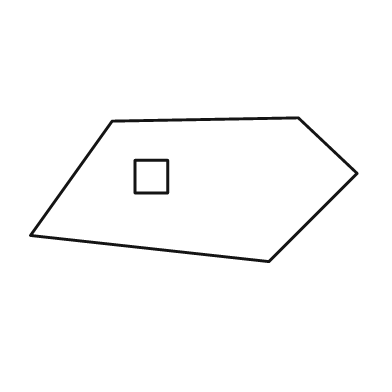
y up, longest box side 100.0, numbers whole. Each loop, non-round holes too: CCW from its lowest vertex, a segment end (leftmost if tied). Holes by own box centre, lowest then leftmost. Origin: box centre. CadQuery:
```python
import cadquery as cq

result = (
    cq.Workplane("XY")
    .moveTo(23.0, -22.0)
    .lineTo(50.0, 5.0)
    .lineTo(32.0, 22.0)
    .lineTo(-25.0, 21.0)
    .lineTo(-50.0, -14.0)
    .close()
    .moveTo(-18.0, -1.0)
    .lineTo(-8.0, -1.0)
    .lineTo(-8.0, 9.0)
    .lineTo(-18.0, 9.0)
    .close()
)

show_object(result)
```